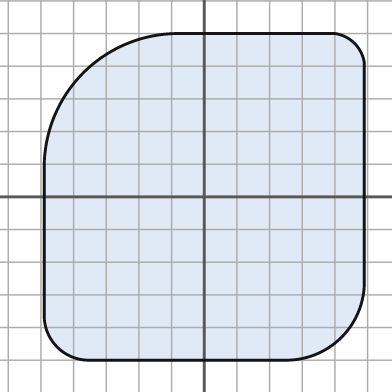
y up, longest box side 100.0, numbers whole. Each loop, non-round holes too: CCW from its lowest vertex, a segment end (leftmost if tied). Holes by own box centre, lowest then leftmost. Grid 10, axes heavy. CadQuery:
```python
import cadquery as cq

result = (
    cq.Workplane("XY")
    .moveTo(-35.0, -50.0)
    .lineTo(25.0, -50.0)
    .threePointArc((42.0, -43.0), (49.0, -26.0))
    .lineTo(49.0, 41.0)
    .threePointArc((46.0, 47.0), (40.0, 50.0))
    .lineTo(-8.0, 50.0)
    .threePointArc((-37.0, 38.0), (-49.0, 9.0))
    .lineTo(-49.0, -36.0)
    .threePointArc((-45.0, -46.0), (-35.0, -50.0))
    .close()
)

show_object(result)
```